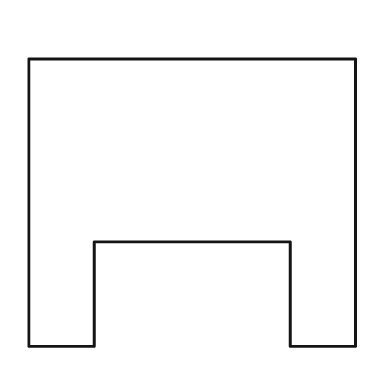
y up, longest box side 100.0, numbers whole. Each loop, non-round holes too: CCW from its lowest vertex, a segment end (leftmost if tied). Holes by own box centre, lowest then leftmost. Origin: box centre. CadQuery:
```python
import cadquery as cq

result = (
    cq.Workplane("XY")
    .moveTo(-50.0, -44.0)
    .lineTo(-30.0, -44.0)
    .lineTo(-30.0, -12.0)
    .lineTo(30.0, -12.0)
    .lineTo(30.0, -44.0)
    .lineTo(50.0, -44.0)
    .lineTo(50.0, 44.0)
    .lineTo(-50.0, 44.0)
    .close()
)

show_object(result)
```